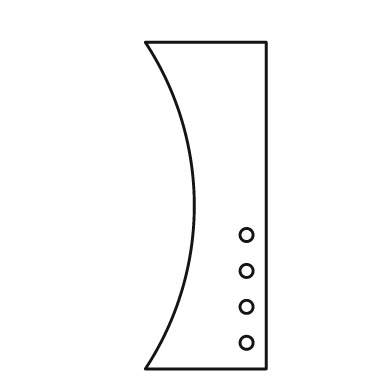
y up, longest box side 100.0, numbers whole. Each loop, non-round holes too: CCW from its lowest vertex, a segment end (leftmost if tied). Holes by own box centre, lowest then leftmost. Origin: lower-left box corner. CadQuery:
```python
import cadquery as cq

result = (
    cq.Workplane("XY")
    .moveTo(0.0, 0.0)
    .lineTo(37.0, 0.0)
    .lineTo(37.0, 100.0)
    .lineTo(0.0, 100.0)
    .threePointArc((15.0, 50.0), (0.0, 0.0))
    .close()
    .moveTo(31.0, 8.0)
    .circle(2.0)
    .moveTo(31.0, 19.0)
    .circle(2.0)
    .moveTo(31.0, 30.0)
    .circle(2.0)
    .moveTo(31.0, 41.0)
    .circle(2.0)
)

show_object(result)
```